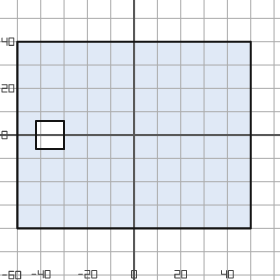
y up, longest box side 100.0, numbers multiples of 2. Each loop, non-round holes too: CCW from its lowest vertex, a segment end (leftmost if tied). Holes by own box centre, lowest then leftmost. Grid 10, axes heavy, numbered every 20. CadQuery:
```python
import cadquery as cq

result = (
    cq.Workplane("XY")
    .moveTo(-50.0, -40.0)
    .lineTo(50.0, -40.0)
    .lineTo(50.0, 40.0)
    .lineTo(-50.0, 40.0)
    .close()
    .moveTo(-42.0, -6.0)
    .lineTo(-30.0, -6.0)
    .lineTo(-30.0, 6.0)
    .lineTo(-42.0, 6.0)
    .close()
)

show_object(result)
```